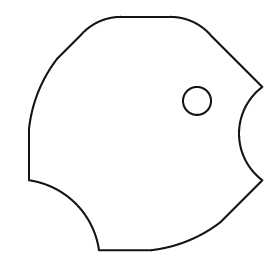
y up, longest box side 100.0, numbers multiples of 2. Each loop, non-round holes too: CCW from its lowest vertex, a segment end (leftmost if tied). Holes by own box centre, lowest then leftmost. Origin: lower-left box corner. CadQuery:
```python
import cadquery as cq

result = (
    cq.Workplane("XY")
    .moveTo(30.0, 0.0)
    .lineTo(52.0, 0.0)
    .threePointArc((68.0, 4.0), (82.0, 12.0))
    .lineTo(100.0, 30.0)
    .threePointArc((90.0, 50.0), (100.0, 70.0))
    .lineTo(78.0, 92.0)
    .threePointArc((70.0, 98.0), (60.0, 100.0))
    .lineTo(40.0, 100.0)
    .threePointArc((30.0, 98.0), (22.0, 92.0))
    .lineTo(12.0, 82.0)
    .threePointArc((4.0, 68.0), (0.0, 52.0))
    .lineTo(0.0, 30.0)
    .threePointArc((20.0, 20.0), (30.0, 0.0))
    .close()
    .moveTo(72.0, 64.0)
    .circle(6.0)
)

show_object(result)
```